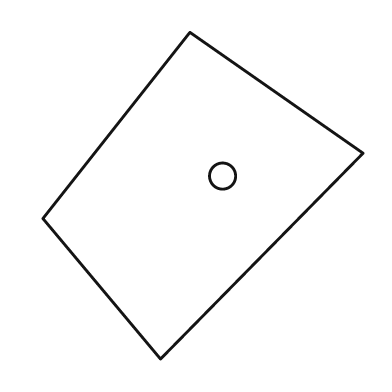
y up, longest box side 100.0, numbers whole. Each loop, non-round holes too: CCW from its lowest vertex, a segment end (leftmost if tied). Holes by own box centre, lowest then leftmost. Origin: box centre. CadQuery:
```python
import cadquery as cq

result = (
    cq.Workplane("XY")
    .moveTo(-13.0, -50.0)
    .lineTo(49.0, 13.0)
    .lineTo(-4.0, 50.0)
    .lineTo(-49.0, -7.0)
    .close()
    .moveTo(6.0, 6.0)
    .circle(4.0)
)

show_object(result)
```